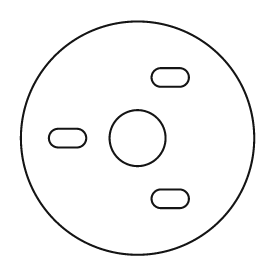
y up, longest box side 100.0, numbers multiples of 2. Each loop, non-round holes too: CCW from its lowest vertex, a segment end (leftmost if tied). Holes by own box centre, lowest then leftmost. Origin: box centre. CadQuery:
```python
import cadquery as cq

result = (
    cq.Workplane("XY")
    .moveTo(0.0, 0.0)
    .circle(50.0)
    .moveTo(10.0, -30.0)
    .lineTo(18.0, -30.0)
    .threePointArc((22.0, -26.0), (18.0, -22.0))
    .lineTo(10.0, -22.0)
    .threePointArc((6.0, -26.0), (10.0, -30.0))
    .close()
    .moveTo(-34.0, -4.0)
    .lineTo(-26.0, -4.0)
    .threePointArc((-22.0, 0.0), (-26.0, 4.0))
    .lineTo(-34.0, 4.0)
    .threePointArc((-38.0, 0.0), (-34.0, -4.0))
    .close()
    .moveTo(0.0, 0.0)
    .circle(12.0)
    .moveTo(10.0, 22.0)
    .lineTo(18.0, 22.0)
    .threePointArc((22.0, 26.0), (18.0, 30.0))
    .lineTo(10.0, 30.0)
    .threePointArc((6.0, 26.0), (10.0, 22.0))
    .close()
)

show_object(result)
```